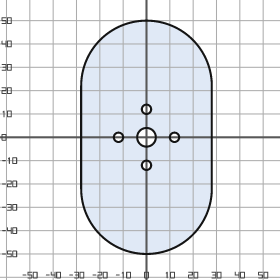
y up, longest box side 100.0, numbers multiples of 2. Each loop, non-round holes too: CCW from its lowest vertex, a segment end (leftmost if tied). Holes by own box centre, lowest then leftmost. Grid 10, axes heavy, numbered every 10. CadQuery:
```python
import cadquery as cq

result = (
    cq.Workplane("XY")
    .moveTo(-28.0, -22.0)
    .threePointArc((0.0, -50.0), (28.0, -22.0))
    .lineTo(28.0, 22.0)
    .threePointArc((0.0, 50.0), (-28.0, 22.0))
    .close()
    .moveTo(0.0, -12.0)
    .circle(2.0)
    .moveTo(-12.0, 0.0)
    .circle(2.0)
    .moveTo(0.0, 0.0)
    .circle(4.0)
    .moveTo(12.0, 0.0)
    .circle(2.0)
    .moveTo(0.0, 12.0)
    .circle(2.0)
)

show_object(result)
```